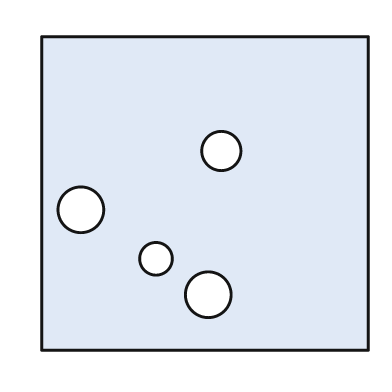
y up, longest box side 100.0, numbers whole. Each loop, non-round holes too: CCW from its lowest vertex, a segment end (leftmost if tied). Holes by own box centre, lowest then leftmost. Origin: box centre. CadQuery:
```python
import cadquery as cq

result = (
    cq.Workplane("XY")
    .moveTo(-50.0, -48.0)
    .lineTo(50.0, -48.0)
    .lineTo(50.0, 48.0)
    .lineTo(-50.0, 48.0)
    .close()
    .moveTo(1.0, -31.0)
    .circle(7.0)
    .moveTo(-15.0, -20.0)
    .circle(5.0)
    .moveTo(-38.0, -5.0)
    .circle(7.0)
    .moveTo(5.0, 13.0)
    .circle(6.0)
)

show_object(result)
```